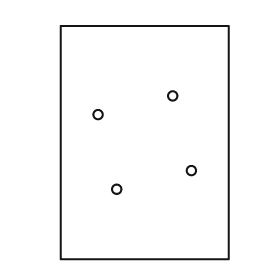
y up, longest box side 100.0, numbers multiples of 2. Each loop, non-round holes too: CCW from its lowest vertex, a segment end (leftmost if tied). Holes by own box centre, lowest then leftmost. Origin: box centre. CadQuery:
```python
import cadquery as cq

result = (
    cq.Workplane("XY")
    .moveTo(-36.0, -50.0)
    .lineTo(36.0, -50.0)
    .lineTo(36.0, 50.0)
    .lineTo(-36.0, 50.0)
    .close()
    .moveTo(-12.0, -20.0)
    .circle(2.0)
    .moveTo(20.0, -12.0)
    .circle(2.0)
    .moveTo(-20.0, 12.0)
    .circle(2.0)
    .moveTo(12.0, 20.0)
    .circle(2.0)
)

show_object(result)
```